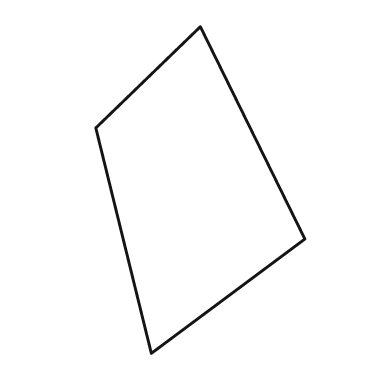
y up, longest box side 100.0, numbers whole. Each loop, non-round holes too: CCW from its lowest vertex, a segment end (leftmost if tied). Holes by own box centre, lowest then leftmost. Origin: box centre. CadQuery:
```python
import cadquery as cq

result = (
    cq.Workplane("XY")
    .moveTo(-15.0, -50.0)
    .lineTo(32.0, -15.0)
    .lineTo(0.0, 50.0)
    .lineTo(-32.0, 19.0)
    .close()
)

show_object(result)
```